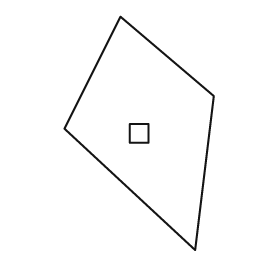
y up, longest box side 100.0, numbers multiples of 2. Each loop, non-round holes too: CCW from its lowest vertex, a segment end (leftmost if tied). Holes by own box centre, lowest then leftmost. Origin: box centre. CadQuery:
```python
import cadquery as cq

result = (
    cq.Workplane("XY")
    .moveTo(24.0, -50.0)
    .lineTo(32.0, 16.0)
    .lineTo(-8.0, 50.0)
    .lineTo(-32.0, 2.0)
    .close()
    .moveTo(-4.0, -4.0)
    .lineTo(4.0, -4.0)
    .lineTo(4.0, 4.0)
    .lineTo(-4.0, 4.0)
    .close()
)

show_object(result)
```